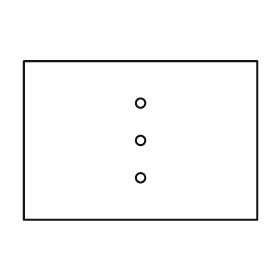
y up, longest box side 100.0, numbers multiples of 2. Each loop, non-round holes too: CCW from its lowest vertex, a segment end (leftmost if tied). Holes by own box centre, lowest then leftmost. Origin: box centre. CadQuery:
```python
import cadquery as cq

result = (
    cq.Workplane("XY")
    .moveTo(-50.0, -34.0)
    .lineTo(50.0, -34.0)
    .lineTo(50.0, 34.0)
    .lineTo(-50.0, 34.0)
    .close()
    .moveTo(0.0, -16.0)
    .circle(2.0)
    .moveTo(0.0, 0.0)
    .circle(2.0)
    .moveTo(0.0, 16.0)
    .circle(2.0)
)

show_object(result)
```